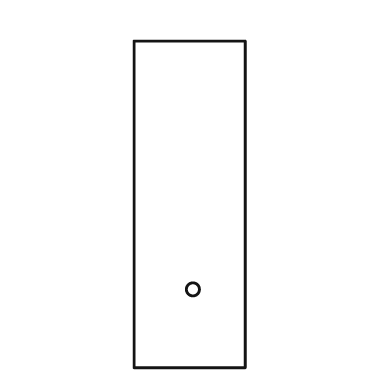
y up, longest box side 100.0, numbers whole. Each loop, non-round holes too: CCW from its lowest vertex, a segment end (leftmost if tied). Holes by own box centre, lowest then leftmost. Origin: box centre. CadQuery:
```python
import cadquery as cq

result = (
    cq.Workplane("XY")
    .moveTo(-17.0, -50.0)
    .lineTo(17.0, -50.0)
    .lineTo(17.0, 50.0)
    .lineTo(-17.0, 50.0)
    .close()
    .moveTo(1.0, -26.0)
    .circle(2.0)
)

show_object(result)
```